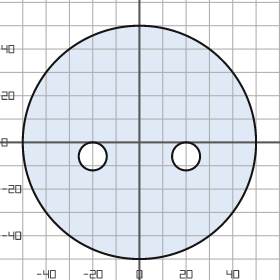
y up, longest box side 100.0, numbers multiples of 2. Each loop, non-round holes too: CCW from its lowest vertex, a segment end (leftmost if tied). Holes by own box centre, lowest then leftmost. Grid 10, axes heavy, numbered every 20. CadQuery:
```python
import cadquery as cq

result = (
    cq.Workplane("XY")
    .moveTo(0.0, 0.0)
    .circle(50.0)
    .moveTo(-20.0, -6.0)
    .circle(6.0)
    .moveTo(20.0, -6.0)
    .circle(6.0)
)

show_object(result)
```